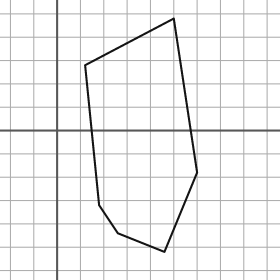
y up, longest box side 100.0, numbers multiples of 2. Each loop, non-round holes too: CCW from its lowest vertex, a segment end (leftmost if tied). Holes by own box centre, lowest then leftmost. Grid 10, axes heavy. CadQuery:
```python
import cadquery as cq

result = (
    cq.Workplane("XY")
    .moveTo(46.0, -52.0)
    .lineTo(60.0, -18.0)
    .lineTo(50.0, 48.0)
    .lineTo(12.0, 28.0)
    .lineTo(18.0, -32.0)
    .lineTo(26.0, -44.0)
    .close()
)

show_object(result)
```